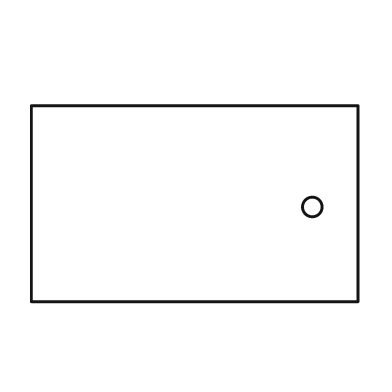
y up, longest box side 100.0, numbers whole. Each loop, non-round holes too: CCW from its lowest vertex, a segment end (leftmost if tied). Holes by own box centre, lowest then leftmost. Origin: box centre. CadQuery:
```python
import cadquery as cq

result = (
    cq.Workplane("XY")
    .moveTo(-50.0, -30.0)
    .lineTo(50.0, -30.0)
    .lineTo(50.0, 30.0)
    .lineTo(-50.0, 30.0)
    .close()
    .moveTo(36.0, -1.0)
    .circle(3.0)
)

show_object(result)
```